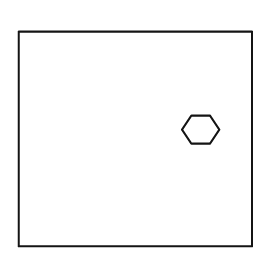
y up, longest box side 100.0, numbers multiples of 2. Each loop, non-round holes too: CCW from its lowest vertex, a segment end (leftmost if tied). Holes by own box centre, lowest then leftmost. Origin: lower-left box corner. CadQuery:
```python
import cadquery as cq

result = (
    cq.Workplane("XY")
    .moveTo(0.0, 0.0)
    .lineTo(100.0, 0.0)
    .lineTo(100.0, 92.0)
    .lineTo(0.0, 92.0)
    .close()
    .moveTo(74.0, 44.0)
    .lineTo(82.0, 44.0)
    .lineTo(86.0, 50.0)
    .lineTo(82.0, 56.0)
    .lineTo(74.0, 56.0)
    .lineTo(70.0, 50.0)
    .close()
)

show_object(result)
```